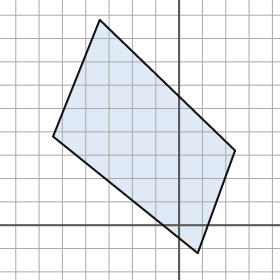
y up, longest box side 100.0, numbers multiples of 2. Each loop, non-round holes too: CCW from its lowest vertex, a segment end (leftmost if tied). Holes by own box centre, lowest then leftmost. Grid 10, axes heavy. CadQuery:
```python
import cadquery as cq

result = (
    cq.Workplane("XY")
    .moveTo(8.0, -12.0)
    .lineTo(24.0, 32.0)
    .lineTo(-34.0, 88.0)
    .lineTo(-54.0, 38.0)
    .close()
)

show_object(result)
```